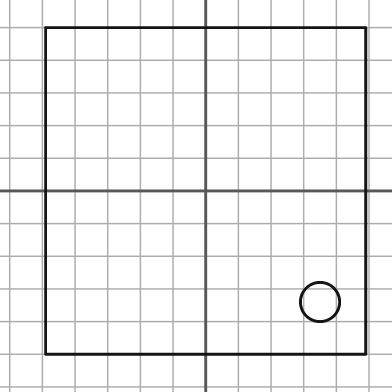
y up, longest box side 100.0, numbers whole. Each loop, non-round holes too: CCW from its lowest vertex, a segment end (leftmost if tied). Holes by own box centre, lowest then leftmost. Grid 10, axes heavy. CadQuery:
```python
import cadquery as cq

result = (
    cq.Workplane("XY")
    .moveTo(-49.0, -50.0)
    .lineTo(49.0, -50.0)
    .lineTo(49.0, 50.0)
    .lineTo(-49.0, 50.0)
    .close()
    .moveTo(35.0, -34.0)
    .circle(6.0)
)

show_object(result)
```